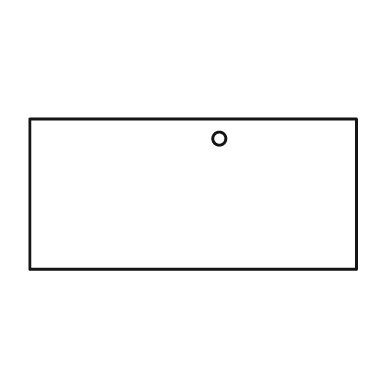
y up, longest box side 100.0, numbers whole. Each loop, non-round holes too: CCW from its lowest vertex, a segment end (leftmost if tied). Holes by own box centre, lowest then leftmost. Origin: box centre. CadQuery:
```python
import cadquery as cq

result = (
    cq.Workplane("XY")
    .moveTo(-50.0, -23.0)
    .lineTo(50.0, -23.0)
    .lineTo(50.0, 23.0)
    .lineTo(-50.0, 23.0)
    .close()
    .moveTo(8.0, 17.0)
    .circle(2.0)
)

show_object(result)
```